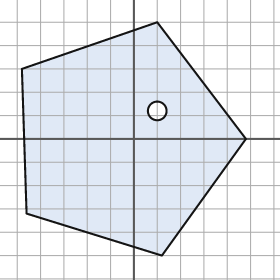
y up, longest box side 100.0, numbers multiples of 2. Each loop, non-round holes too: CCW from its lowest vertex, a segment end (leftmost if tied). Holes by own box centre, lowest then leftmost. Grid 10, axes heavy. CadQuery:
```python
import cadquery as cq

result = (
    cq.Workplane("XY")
    .moveTo(12.0, -50.0)
    .lineTo(48.0, 0.0)
    .lineTo(10.0, 50.0)
    .lineTo(-48.0, 30.0)
    .lineTo(-46.0, -32.0)
    .close()
    .moveTo(10.0, 12.0)
    .circle(4.0)
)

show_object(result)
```